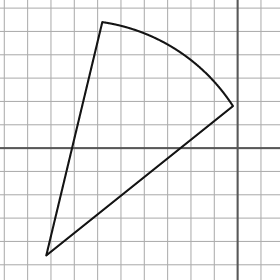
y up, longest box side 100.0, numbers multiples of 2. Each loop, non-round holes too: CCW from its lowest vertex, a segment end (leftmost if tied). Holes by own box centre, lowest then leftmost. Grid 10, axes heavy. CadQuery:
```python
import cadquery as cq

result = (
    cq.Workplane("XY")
    .moveTo(-82.0, -46.0)
    .lineTo(-2.0, 18.0)
    .threePointArc((-26.0, 42.0), (-58.0, 54.0))
    .close()
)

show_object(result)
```